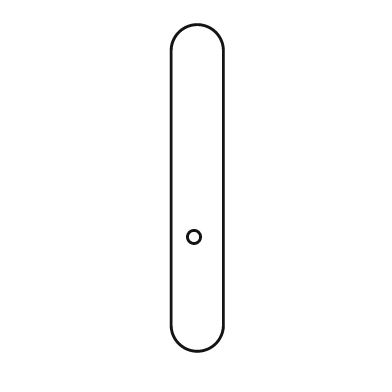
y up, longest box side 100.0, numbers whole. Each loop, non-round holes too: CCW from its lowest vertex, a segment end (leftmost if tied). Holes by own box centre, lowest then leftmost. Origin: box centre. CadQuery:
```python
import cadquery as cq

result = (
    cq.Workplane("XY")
    .moveTo(-8.0, -42.0)
    .threePointArc((0.0, -50.0), (8.0, -42.0))
    .lineTo(8.0, 42.0)
    .threePointArc((0.0, 50.0), (-8.0, 42.0))
    .close()
    .moveTo(-1.0, -15.0)
    .circle(2.0)
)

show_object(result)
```